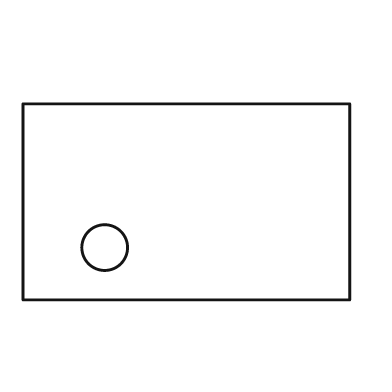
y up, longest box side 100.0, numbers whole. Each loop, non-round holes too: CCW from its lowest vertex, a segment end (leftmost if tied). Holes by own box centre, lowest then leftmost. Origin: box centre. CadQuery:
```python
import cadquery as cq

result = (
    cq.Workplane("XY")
    .moveTo(-50.0, -30.0)
    .lineTo(50.0, -30.0)
    .lineTo(50.0, 30.0)
    .lineTo(-50.0, 30.0)
    .close()
    .moveTo(-25.0, -14.0)
    .circle(7.0)
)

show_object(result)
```